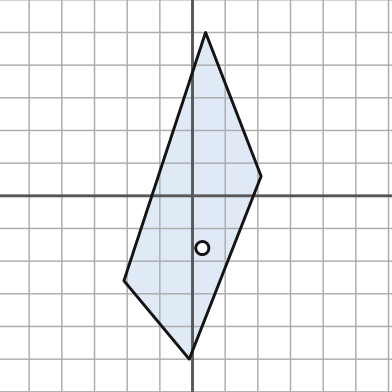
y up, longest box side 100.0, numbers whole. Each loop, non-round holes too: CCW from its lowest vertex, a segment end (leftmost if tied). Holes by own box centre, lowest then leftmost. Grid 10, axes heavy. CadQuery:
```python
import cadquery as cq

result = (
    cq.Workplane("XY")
    .moveTo(-1.0, -50.0)
    .lineTo(21.0, 6.0)
    .lineTo(4.0, 50.0)
    .lineTo(-21.0, -26.0)
    .close()
    .moveTo(3.0, -16.0)
    .circle(2.0)
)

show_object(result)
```